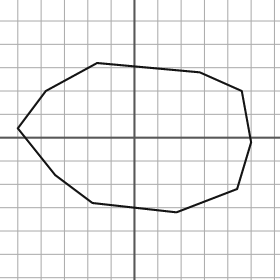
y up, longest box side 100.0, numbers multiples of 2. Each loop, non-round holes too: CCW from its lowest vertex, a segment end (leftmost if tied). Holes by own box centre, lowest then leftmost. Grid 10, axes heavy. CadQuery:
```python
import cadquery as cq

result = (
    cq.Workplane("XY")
    .moveTo(18.0, -32.0)
    .lineTo(44.0, -22.0)
    .lineTo(50.0, -2.0)
    .lineTo(46.0, 20.0)
    .lineTo(28.0, 28.0)
    .lineTo(-16.0, 32.0)
    .lineTo(-38.0, 20.0)
    .lineTo(-50.0, 4.0)
    .lineTo(-34.0, -16.0)
    .lineTo(-18.0, -28.0)
    .close()
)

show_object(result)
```